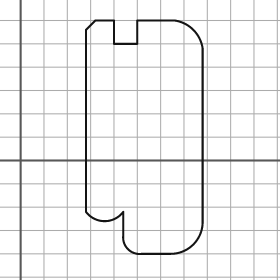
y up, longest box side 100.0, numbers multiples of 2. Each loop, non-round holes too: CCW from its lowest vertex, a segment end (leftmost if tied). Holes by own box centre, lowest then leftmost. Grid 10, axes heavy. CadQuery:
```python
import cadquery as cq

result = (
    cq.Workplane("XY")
    .moveTo(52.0, -40.0)
    .lineTo(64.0, -40.0)
    .threePointArc((74.0, -36.0), (78.0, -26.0))
    .lineTo(78.0, 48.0)
    .threePointArc((74.0, 56.0), (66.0, 60.0))
    .lineTo(50.0, 60.0)
    .lineTo(50.0, 50.0)
    .lineTo(40.0, 50.0)
    .lineTo(40.0, 60.0)
    .lineTo(32.0, 60.0)
    .lineTo(28.0, 56.0)
    .lineTo(28.0, -22.0)
    .threePointArc((36.0, -26.0), (44.0, -22.0))
    .lineTo(44.0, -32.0)
    .threePointArc((46.0, -38.0), (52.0, -40.0))
    .close()
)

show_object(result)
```